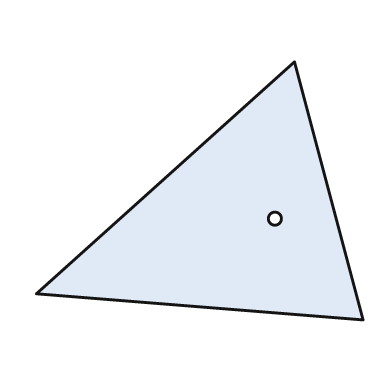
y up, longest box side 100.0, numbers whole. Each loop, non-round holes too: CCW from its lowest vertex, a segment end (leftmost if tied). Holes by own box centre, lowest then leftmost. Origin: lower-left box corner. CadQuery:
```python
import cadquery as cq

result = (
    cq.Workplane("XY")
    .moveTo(100.0, 0.0)
    .lineTo(79.0, 79.0)
    .lineTo(0.0, 8.0)
    .close()
    .moveTo(73.0, 31.0)
    .circle(2.0)
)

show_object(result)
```